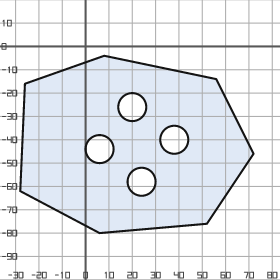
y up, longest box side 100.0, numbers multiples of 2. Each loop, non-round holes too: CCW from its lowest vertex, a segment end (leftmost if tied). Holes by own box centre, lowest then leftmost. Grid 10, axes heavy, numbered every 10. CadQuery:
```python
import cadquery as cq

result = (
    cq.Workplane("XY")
    .moveTo(6.0, -80.0)
    .lineTo(52.0, -76.0)
    .lineTo(72.0, -46.0)
    .lineTo(56.0, -14.0)
    .lineTo(8.0, -4.0)
    .lineTo(-26.0, -16.0)
    .lineTo(-28.0, -62.0)
    .close()
    .moveTo(24.0, -58.0)
    .circle(6.0)
    .moveTo(6.0, -44.0)
    .circle(6.0)
    .moveTo(38.0, -40.0)
    .circle(6.0)
    .moveTo(20.0, -26.0)
    .circle(6.0)
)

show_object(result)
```